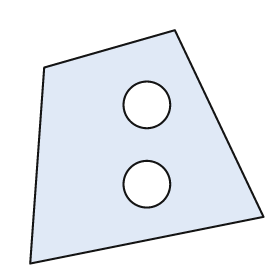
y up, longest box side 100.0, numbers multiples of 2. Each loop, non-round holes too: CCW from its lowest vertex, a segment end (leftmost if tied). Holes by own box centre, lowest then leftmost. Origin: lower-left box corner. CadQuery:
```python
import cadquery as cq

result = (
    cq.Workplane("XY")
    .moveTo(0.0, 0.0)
    .lineTo(100.0, 20.0)
    .lineTo(62.0, 100.0)
    .lineTo(6.0, 84.0)
    .close()
    .moveTo(50.0, 34.0)
    .circle(10.0)
    .moveTo(50.0, 68.0)
    .circle(10.0)
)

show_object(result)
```